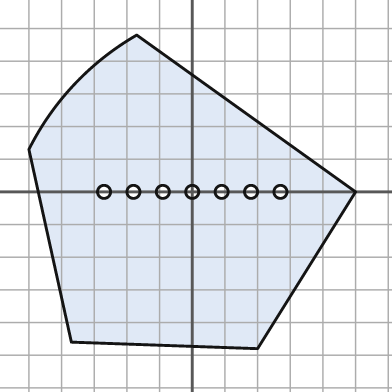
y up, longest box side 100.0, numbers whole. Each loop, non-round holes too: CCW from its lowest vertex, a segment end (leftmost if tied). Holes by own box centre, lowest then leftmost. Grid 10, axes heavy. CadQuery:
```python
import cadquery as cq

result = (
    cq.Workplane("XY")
    .moveTo(20.0, -48.0)
    .lineTo(50.0, 0.0)
    .lineTo(-17.0, 48.0)
    .threePointArc((-36.0, 33.0), (-50.0, 13.0))
    .lineTo(-37.0, -46.0)
    .close()
    .moveTo(-27.0, 0.0)
    .circle(2.0)
    .moveTo(-18.0, 0.0)
    .circle(2.0)
    .moveTo(-9.0, 0.0)
    .circle(2.0)
    .moveTo(0.0, 0.0)
    .circle(2.0)
    .moveTo(9.0, 0.0)
    .circle(2.0)
    .moveTo(18.0, 0.0)
    .circle(2.0)
    .moveTo(27.0, 0.0)
    .circle(2.0)
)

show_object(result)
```